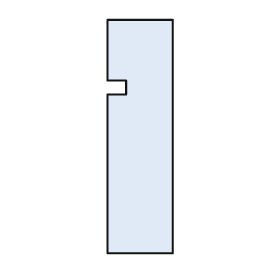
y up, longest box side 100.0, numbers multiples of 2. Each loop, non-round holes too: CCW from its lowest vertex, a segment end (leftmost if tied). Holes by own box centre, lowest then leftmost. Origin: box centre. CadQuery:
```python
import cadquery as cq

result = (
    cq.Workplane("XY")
    .moveTo(-14.0, -50.0)
    .lineTo(14.0, -50.0)
    .lineTo(14.0, 50.0)
    .lineTo(-14.0, 50.0)
    .lineTo(-14.0, 24.0)
    .lineTo(-6.0, 24.0)
    .lineTo(-6.0, 18.0)
    .lineTo(-14.0, 18.0)
    .close()
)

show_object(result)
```